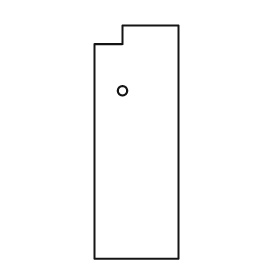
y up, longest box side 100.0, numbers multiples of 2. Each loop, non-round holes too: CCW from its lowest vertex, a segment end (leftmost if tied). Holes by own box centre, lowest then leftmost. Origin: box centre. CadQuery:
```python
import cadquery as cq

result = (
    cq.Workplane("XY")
    .moveTo(-18.0, -50.0)
    .lineTo(18.0, -50.0)
    .lineTo(18.0, 50.0)
    .lineTo(-6.0, 50.0)
    .lineTo(-6.0, 42.0)
    .lineTo(-18.0, 42.0)
    .close()
    .moveTo(-6.0, 22.0)
    .circle(2.0)
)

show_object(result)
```